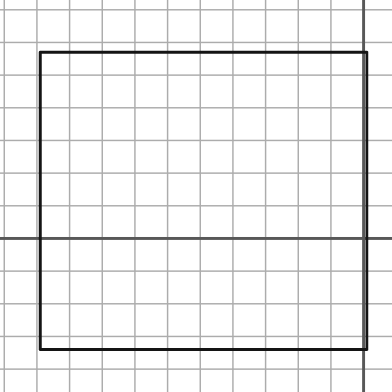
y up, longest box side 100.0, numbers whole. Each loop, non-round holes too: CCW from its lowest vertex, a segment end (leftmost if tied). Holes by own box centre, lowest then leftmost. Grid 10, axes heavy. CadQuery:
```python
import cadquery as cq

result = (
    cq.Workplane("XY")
    .moveTo(-99.0, -34.0)
    .lineTo(1.0, -34.0)
    .lineTo(1.0, 57.0)
    .lineTo(-99.0, 57.0)
    .close()
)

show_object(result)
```